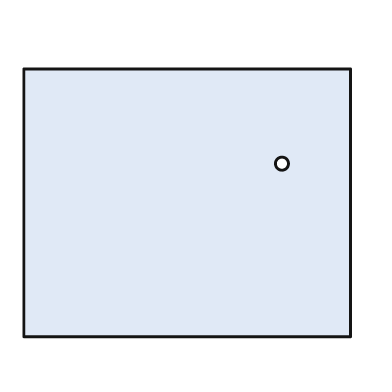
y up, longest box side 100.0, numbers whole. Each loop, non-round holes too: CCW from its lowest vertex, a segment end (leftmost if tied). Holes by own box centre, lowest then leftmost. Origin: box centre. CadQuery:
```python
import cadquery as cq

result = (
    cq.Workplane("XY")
    .moveTo(-50.0, -41.0)
    .lineTo(50.0, -41.0)
    .lineTo(50.0, 41.0)
    .lineTo(-50.0, 41.0)
    .close()
    .moveTo(29.0, 12.0)
    .circle(2.0)
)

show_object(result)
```